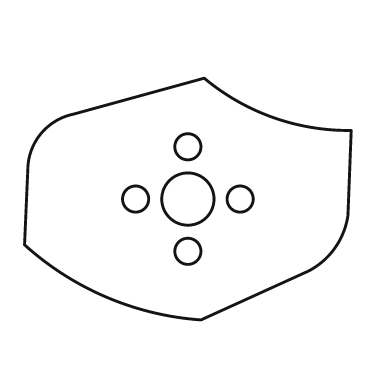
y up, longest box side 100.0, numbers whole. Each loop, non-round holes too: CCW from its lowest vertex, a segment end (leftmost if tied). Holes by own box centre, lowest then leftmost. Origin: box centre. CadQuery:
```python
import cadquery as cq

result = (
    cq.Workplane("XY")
    .moveTo(4.0, -37.0)
    .lineTo(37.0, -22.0)
    .threePointArc((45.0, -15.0), (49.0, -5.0))
    .lineTo(50.0, 21.0)
    .threePointArc((26.0, 25.0), (5.0, 37.0))
    .lineTo(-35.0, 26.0)
    .threePointArc((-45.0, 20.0), (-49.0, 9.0))
    .lineTo(-50.0, -14.0)
    .threePointArc((-25.0, -30.0), (4.0, -37.0))
    .close()
    .moveTo(0.0, -16.0)
    .circle(4.0)
    .moveTo(-16.0, 0.0)
    .circle(4.0)
    .moveTo(0.0, 0.0)
    .circle(8.0)
    .moveTo(16.0, 0.0)
    .circle(4.0)
    .moveTo(0.0, 16.0)
    .circle(4.0)
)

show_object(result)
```